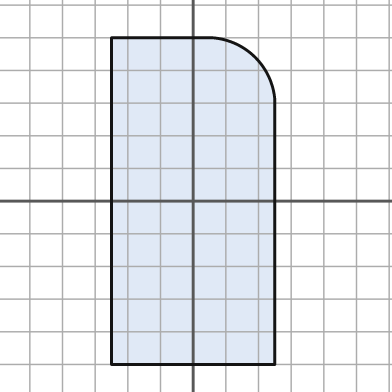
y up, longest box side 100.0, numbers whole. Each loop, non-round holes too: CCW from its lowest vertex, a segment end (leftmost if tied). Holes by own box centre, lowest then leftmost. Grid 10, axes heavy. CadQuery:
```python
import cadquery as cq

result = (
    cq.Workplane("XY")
    .moveTo(-25.0, -50.0)
    .lineTo(25.0, -50.0)
    .lineTo(25.0, 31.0)
    .threePointArc((19.0, 44.0), (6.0, 50.0))
    .lineTo(-25.0, 50.0)
    .close()
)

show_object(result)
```